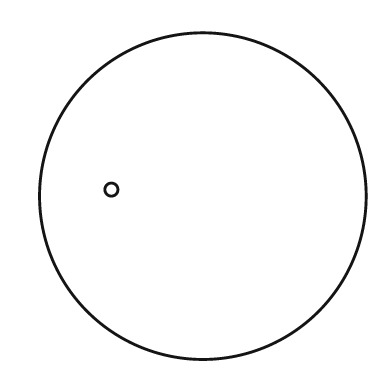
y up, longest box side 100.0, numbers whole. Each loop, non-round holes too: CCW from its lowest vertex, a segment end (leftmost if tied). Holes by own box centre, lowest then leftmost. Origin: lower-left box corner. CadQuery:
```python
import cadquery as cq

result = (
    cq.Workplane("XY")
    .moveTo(50.0, 50.0)
    .circle(50.0)
    .moveTo(22.0, 52.0)
    .circle(2.0)
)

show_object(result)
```